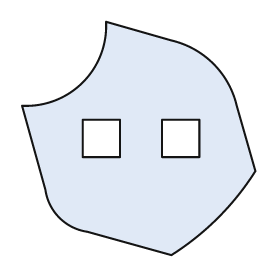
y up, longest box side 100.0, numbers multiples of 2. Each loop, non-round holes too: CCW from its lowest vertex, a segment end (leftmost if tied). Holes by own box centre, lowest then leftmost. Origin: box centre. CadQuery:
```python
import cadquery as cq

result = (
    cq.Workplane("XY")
    .moveTo(14.0, -50.0)
    .threePointArc((34.0, -34.0), (50.0, -14.0))
    .lineTo(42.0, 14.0)
    .threePointArc((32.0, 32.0), (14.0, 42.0))
    .lineTo(-14.0, 50.0)
    .threePointArc((-24.0, 24.0), (-50.0, 14.0))
    .lineTo(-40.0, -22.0)
    .threePointArc((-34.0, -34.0), (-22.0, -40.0))
    .close()
    .moveTo(-24.0, -8.0)
    .lineTo(-8.0, -8.0)
    .lineTo(-8.0, 8.0)
    .lineTo(-24.0, 8.0)
    .close()
    .moveTo(10.0, -8.0)
    .lineTo(26.0, -8.0)
    .lineTo(26.0, 8.0)
    .lineTo(10.0, 8.0)
    .close()
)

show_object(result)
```